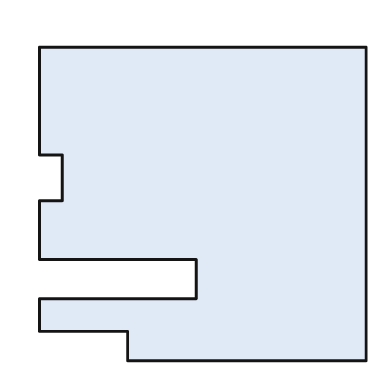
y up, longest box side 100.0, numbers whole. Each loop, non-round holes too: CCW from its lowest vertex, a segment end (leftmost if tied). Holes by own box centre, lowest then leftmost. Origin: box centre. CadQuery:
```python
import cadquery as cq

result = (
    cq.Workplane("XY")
    .moveTo(-23.0, -48.0)
    .lineTo(50.0, -48.0)
    .lineTo(50.0, 48.0)
    .lineTo(-50.0, 48.0)
    .lineTo(-50.0, 15.0)
    .lineTo(-43.0, 15.0)
    .lineTo(-43.0, 1.0)
    .lineTo(-50.0, 1.0)
    .lineTo(-50.0, -17.0)
    .lineTo(-2.0, -17.0)
    .lineTo(-2.0, -29.0)
    .lineTo(-50.0, -29.0)
    .lineTo(-50.0, -39.0)
    .lineTo(-23.0, -39.0)
    .close()
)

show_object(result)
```